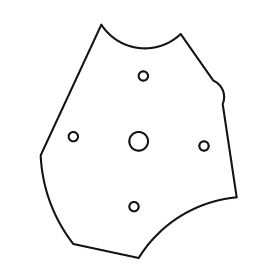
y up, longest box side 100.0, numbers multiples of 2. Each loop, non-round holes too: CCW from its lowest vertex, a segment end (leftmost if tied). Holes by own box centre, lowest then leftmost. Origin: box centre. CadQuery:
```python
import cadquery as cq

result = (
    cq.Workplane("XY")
    .moveTo(0.0, -50.0)
    .threePointArc((18.0, -32.0), (42.0, -24.0))
    .lineTo(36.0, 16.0)
    .threePointArc((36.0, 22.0), (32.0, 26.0))
    .lineTo(18.0, 46.0)
    .threePointArc((0.0, 40.0), (-16.0, 50.0))
    .lineTo(-42.0, -6.0)
    .threePointArc((-38.0, -26.0), (-28.0, -44.0))
    .close()
    .moveTo(-2.0, -28.0)
    .circle(2.0)
    .moveTo(28.0, -2.0)
    .circle(2.0)
    .moveTo(0.0, 0.0)
    .circle(4.0)
    .moveTo(-28.0, 2.0)
    .circle(2.0)
    .moveTo(2.0, 28.0)
    .circle(2.0)
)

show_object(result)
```